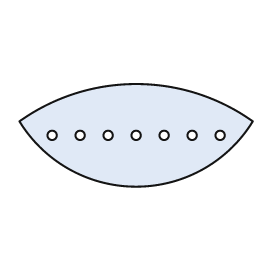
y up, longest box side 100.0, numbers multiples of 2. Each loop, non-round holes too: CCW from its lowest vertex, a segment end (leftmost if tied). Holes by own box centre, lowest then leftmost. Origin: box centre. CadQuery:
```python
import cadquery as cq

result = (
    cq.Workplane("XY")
    .moveTo(-50.0, 6.0)
    .threePointArc((0.0, -22.0), (50.0, 6.0))
    .threePointArc((0.0, 22.0), (-50.0, 6.0))
    .close()
    .moveTo(-36.0, 0.0)
    .circle(2.0)
    .moveTo(-24.0, 0.0)
    .circle(2.0)
    .moveTo(-12.0, 0.0)
    .circle(2.0)
    .moveTo(0.0, 0.0)
    .circle(2.0)
    .moveTo(12.0, 0.0)
    .circle(2.0)
    .moveTo(24.0, 0.0)
    .circle(2.0)
    .moveTo(36.0, 0.0)
    .circle(2.0)
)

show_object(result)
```